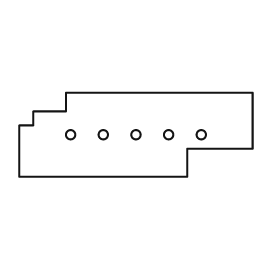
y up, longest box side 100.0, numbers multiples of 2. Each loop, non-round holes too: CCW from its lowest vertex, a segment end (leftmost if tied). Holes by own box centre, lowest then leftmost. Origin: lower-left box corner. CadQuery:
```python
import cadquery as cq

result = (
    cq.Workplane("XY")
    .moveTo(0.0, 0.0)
    .lineTo(72.0, 0.0)
    .lineTo(72.0, 12.0)
    .lineTo(100.0, 12.0)
    .lineTo(100.0, 36.0)
    .lineTo(20.0, 36.0)
    .lineTo(20.0, 28.0)
    .lineTo(6.0, 28.0)
    .lineTo(6.0, 22.0)
    .lineTo(0.0, 22.0)
    .close()
    .moveTo(22.0, 18.0)
    .circle(2.0)
    .moveTo(36.0, 18.0)
    .circle(2.0)
    .moveTo(50.0, 18.0)
    .circle(2.0)
    .moveTo(64.0, 18.0)
    .circle(2.0)
    .moveTo(78.0, 18.0)
    .circle(2.0)
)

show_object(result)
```